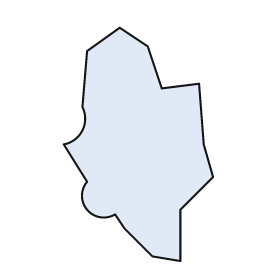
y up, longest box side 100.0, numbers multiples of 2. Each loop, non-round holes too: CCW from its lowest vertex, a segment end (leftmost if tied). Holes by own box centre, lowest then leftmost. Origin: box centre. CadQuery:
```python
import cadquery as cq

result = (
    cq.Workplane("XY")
    .moveTo(18.0, -50.0)
    .lineTo(18.0, -28.0)
    .lineTo(32.0, -14.0)
    .lineTo(28.0, 0.0)
    .lineTo(26.0, 26.0)
    .lineTo(10.0, 24.0)
    .lineTo(4.0, 42.0)
    .lineTo(-8.0, 50.0)
    .lineTo(-22.0, 40.0)
    .lineTo(-24.0, 16.0)
    .threePointArc((-24.0, 6.0), (-32.0, 0.0))
    .lineTo(-22.0, -16.0)
    .threePointArc((-22.0, -28.0), (-10.0, -30.0))
    .lineTo(-6.0, -36.0)
    .lineTo(6.0, -48.0)
    .close()
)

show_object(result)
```